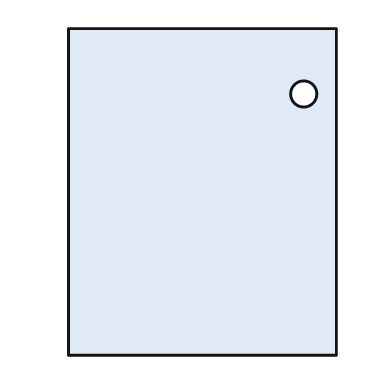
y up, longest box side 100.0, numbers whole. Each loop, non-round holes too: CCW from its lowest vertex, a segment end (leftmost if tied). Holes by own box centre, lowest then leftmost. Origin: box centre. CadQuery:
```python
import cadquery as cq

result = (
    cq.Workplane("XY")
    .moveTo(-41.0, -50.0)
    .lineTo(41.0, -50.0)
    .lineTo(41.0, 50.0)
    .lineTo(-41.0, 50.0)
    .close()
    .moveTo(31.0, 30.0)
    .circle(4.0)
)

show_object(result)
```